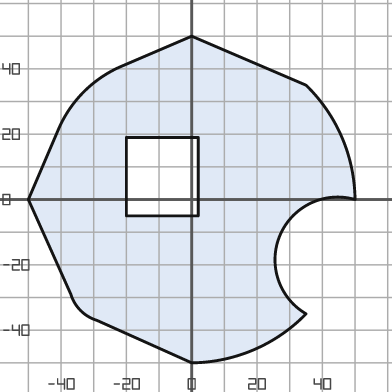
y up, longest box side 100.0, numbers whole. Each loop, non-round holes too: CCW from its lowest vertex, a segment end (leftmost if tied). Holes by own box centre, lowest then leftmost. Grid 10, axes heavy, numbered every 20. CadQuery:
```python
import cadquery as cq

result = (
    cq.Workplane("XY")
    .moveTo(0.0, -50.0)
    .threePointArc((19.0, -46.0), (35.0, -35.0))
    .threePointArc((27.0, -11.0), (50.0, 0.0))
    .threePointArc((46.0, 19.0), (35.0, 35.0))
    .lineTo(0.0, 50.0)
    .lineTo(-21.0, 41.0)
    .threePointArc((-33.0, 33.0), (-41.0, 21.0))
    .lineTo(-50.0, 0.0)
    .lineTo(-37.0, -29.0)
    .threePointArc((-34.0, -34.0), (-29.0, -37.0))
    .close()
    .moveTo(-20.0, -5.0)
    .lineTo(2.0, -5.0)
    .lineTo(2.0, 19.0)
    .lineTo(-20.0, 19.0)
    .close()
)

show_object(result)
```